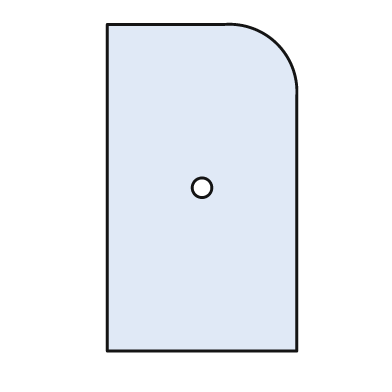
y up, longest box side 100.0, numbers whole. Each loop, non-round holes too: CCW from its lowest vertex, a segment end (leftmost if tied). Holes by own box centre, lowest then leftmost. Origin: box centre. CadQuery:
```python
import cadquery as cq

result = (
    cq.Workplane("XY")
    .moveTo(-29.0, -50.0)
    .lineTo(29.0, -50.0)
    .lineTo(29.0, 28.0)
    .threePointArc((23.0, 44.0), (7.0, 50.0))
    .lineTo(-29.0, 50.0)
    .close()
    .moveTo(0.0, 0.0)
    .circle(3.0)
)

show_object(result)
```